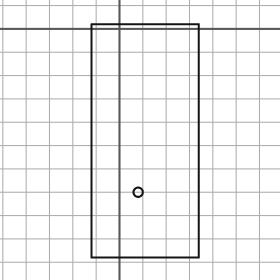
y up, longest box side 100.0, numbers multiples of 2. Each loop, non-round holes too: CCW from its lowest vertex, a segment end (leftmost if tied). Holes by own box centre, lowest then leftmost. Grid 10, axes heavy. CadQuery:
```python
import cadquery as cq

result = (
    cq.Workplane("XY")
    .moveTo(-12.0, -98.0)
    .lineTo(34.0, -98.0)
    .lineTo(34.0, 2.0)
    .lineTo(-12.0, 2.0)
    .close()
    .moveTo(8.0, -70.0)
    .circle(2.0)
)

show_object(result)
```